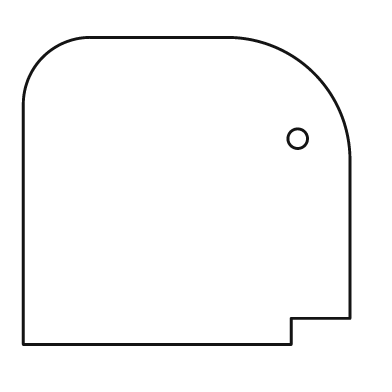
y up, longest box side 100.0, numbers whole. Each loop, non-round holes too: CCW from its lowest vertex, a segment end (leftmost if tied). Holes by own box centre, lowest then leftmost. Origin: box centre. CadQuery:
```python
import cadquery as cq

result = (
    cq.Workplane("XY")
    .moveTo(-50.0, -47.0)
    .lineTo(32.0, -47.0)
    .lineTo(32.0, -39.0)
    .lineTo(50.0, -39.0)
    .lineTo(50.0, 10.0)
    .threePointArc((39.0, 36.0), (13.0, 47.0))
    .lineTo(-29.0, 47.0)
    .threePointArc((-44.0, 41.0), (-50.0, 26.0))
    .close()
    .moveTo(34.0, 16.0)
    .circle(3.0)
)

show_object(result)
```